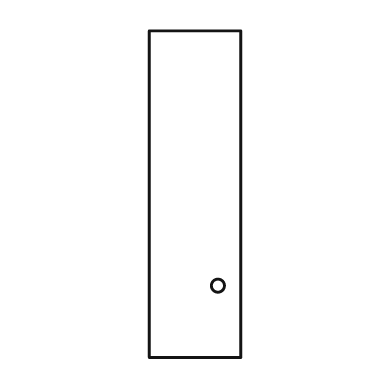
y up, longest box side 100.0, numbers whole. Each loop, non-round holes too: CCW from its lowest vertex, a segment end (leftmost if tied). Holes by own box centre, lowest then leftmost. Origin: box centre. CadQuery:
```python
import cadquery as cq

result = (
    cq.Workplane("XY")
    .moveTo(-14.0, -50.0)
    .lineTo(14.0, -50.0)
    .lineTo(14.0, 50.0)
    .lineTo(-14.0, 50.0)
    .close()
    .moveTo(7.0, -28.0)
    .circle(2.0)
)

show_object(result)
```